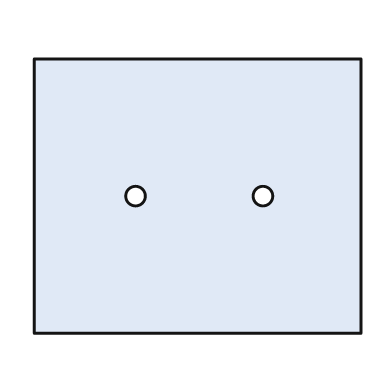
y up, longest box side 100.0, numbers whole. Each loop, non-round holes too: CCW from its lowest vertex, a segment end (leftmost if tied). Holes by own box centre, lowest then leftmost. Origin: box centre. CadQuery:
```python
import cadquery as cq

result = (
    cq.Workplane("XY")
    .moveTo(-50.0, -42.0)
    .lineTo(50.0, -42.0)
    .lineTo(50.0, 42.0)
    .lineTo(-50.0, 42.0)
    .close()
    .moveTo(-19.0, 0.0)
    .circle(3.0)
    .moveTo(20.0, 0.0)
    .circle(3.0)
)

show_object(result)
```